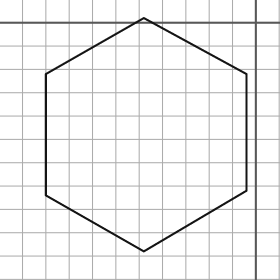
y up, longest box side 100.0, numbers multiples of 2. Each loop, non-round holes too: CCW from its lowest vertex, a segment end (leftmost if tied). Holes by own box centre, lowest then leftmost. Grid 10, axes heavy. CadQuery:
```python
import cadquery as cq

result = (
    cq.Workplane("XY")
    .moveTo(-48.0, -98.0)
    .lineTo(-4.0, -72.0)
    .lineTo(-4.0, -22.0)
    .lineTo(-48.0, 2.0)
    .lineTo(-90.0, -22.0)
    .lineTo(-90.0, -74.0)
    .close()
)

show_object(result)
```